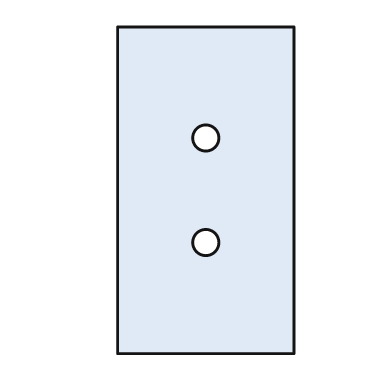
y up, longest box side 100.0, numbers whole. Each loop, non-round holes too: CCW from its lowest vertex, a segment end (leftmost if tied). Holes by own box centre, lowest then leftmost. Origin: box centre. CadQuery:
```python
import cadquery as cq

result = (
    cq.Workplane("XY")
    .moveTo(-27.0, -50.0)
    .lineTo(27.0, -50.0)
    .lineTo(27.0, 50.0)
    .lineTo(-27.0, 50.0)
    .close()
    .moveTo(0.0, -16.0)
    .circle(4.0)
    .moveTo(0.0, 16.0)
    .circle(4.0)
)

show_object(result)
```